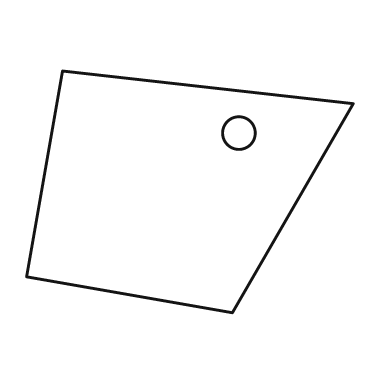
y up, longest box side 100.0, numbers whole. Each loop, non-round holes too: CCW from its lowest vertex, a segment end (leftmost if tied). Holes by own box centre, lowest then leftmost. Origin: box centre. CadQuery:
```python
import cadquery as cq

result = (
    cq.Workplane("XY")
    .moveTo(13.0, -37.0)
    .lineTo(50.0, 27.0)
    .lineTo(-39.0, 37.0)
    .lineTo(-50.0, -26.0)
    .close()
    .moveTo(15.0, 18.0)
    .circle(5.0)
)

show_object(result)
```